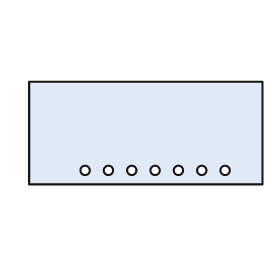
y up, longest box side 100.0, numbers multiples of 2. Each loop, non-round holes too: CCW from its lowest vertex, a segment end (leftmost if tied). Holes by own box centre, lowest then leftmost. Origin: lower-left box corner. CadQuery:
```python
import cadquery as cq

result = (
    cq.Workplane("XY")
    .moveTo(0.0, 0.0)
    .lineTo(100.0, 0.0)
    .lineTo(100.0, 44.0)
    .lineTo(0.0, 44.0)
    .close()
    .moveTo(24.0, 6.0)
    .circle(2.0)
    .moveTo(34.0, 6.0)
    .circle(2.0)
    .moveTo(44.0, 6.0)
    .circle(2.0)
    .moveTo(54.0, 6.0)
    .circle(2.0)
    .moveTo(64.0, 6.0)
    .circle(2.0)
    .moveTo(74.0, 6.0)
    .circle(2.0)
    .moveTo(84.0, 6.0)
    .circle(2.0)
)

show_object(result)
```